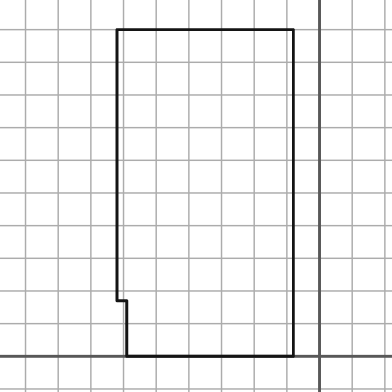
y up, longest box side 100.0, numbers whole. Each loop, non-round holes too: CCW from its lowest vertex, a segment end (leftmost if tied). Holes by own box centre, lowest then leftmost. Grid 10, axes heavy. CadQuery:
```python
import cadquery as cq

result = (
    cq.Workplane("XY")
    .moveTo(-59.0, 0.0)
    .lineTo(-8.0, 0.0)
    .lineTo(-8.0, 100.0)
    .lineTo(-62.0, 100.0)
    .lineTo(-62.0, 17.0)
    .lineTo(-59.0, 17.0)
    .close()
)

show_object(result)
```